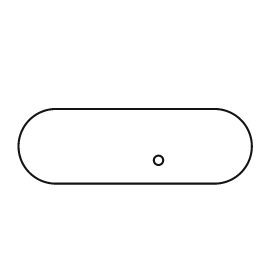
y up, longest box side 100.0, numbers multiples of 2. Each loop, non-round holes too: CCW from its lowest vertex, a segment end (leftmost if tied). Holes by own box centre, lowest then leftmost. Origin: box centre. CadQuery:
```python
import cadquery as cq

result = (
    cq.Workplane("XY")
    .moveTo(-34.0, -16.0)
    .lineTo(34.0, -16.0)
    .threePointArc((50.0, 0.0), (34.0, 16.0))
    .lineTo(-34.0, 16.0)
    .threePointArc((-50.0, 0.0), (-34.0, -16.0))
    .close()
    .moveTo(10.0, -6.0)
    .circle(2.0)
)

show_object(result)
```